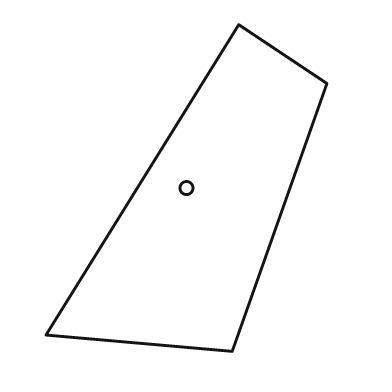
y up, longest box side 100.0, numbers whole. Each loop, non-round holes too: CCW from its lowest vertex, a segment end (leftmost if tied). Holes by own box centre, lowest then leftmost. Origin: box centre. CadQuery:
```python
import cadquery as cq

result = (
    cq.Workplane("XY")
    .moveTo(14.0, -50.0)
    .lineTo(43.0, 32.0)
    .lineTo(16.0, 50.0)
    .lineTo(-43.0, -45.0)
    .close()
    .moveTo(0.0, 0.0)
    .circle(2.0)
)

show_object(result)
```